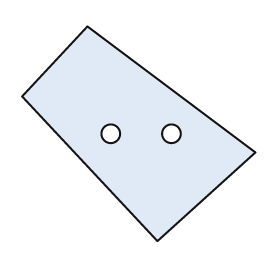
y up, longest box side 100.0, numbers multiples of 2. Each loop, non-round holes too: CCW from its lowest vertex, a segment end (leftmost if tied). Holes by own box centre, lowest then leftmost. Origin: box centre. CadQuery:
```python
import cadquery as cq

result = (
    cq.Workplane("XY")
    .moveTo(8.0, -46.0)
    .lineTo(50.0, -8.0)
    .lineTo(-22.0, 46.0)
    .lineTo(-50.0, 16.0)
    .close()
    .moveTo(-12.0, 0.0)
    .circle(4.0)
    .moveTo(14.0, 0.0)
    .circle(4.0)
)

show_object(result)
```